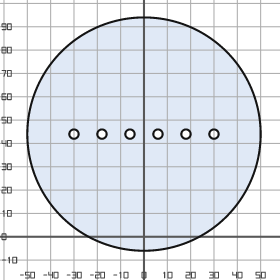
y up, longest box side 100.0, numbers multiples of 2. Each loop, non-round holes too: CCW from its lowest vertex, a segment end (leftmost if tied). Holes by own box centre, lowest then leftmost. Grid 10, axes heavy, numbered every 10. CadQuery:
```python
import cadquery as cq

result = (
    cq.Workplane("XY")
    .moveTo(0.0, 44.0)
    .circle(50.0)
    .moveTo(-30.0, 44.0)
    .circle(2.0)
    .moveTo(-18.0, 44.0)
    .circle(2.0)
    .moveTo(-6.0, 44.0)
    .circle(2.0)
    .moveTo(6.0, 44.0)
    .circle(2.0)
    .moveTo(18.0, 44.0)
    .circle(2.0)
    .moveTo(30.0, 44.0)
    .circle(2.0)
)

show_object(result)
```